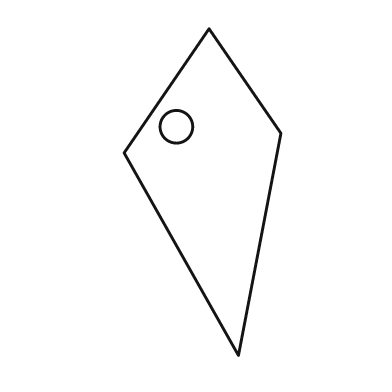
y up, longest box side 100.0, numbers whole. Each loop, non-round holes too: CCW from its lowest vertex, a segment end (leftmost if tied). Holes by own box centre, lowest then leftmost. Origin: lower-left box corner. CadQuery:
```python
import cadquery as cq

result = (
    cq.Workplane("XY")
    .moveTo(35.0, 0.0)
    .lineTo(48.0, 68.0)
    .lineTo(26.0, 100.0)
    .lineTo(0.0, 62.0)
    .close()
    .moveTo(16.0, 70.0)
    .circle(5.0)
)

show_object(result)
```